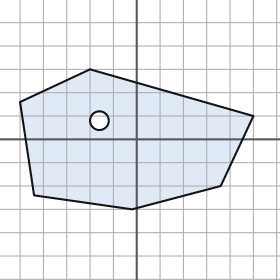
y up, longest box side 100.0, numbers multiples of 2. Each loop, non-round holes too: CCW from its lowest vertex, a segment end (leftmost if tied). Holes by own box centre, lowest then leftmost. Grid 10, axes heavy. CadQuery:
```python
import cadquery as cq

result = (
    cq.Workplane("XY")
    .moveTo(-2.0, -30.0)
    .lineTo(36.0, -20.0)
    .lineTo(50.0, 10.0)
    .lineTo(-20.0, 30.0)
    .lineTo(-50.0, 16.0)
    .lineTo(-44.0, -24.0)
    .close()
    .moveTo(-16.0, 8.0)
    .circle(4.0)
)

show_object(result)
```